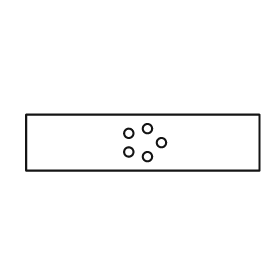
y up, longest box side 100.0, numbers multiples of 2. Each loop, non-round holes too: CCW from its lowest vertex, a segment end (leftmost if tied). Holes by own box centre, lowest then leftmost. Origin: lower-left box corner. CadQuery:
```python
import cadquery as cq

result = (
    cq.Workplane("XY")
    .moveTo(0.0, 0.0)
    .lineTo(100.0, 0.0)
    .lineTo(100.0, 24.0)
    .lineTo(0.0, 24.0)
    .close()
    .moveTo(52.0, 6.0)
    .circle(2.0)
    .moveTo(44.0, 8.0)
    .circle(2.0)
    .moveTo(58.0, 12.0)
    .circle(2.0)
    .moveTo(44.0, 16.0)
    .circle(2.0)
    .moveTo(52.0, 18.0)
    .circle(2.0)
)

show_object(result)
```